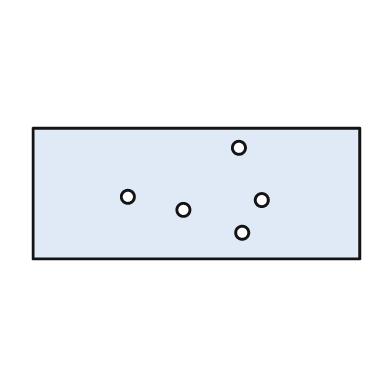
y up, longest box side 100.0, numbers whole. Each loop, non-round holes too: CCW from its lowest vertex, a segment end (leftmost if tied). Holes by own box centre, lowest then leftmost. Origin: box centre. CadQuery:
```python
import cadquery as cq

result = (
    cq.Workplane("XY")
    .moveTo(-50.0, -20.0)
    .lineTo(50.0, -20.0)
    .lineTo(50.0, 20.0)
    .lineTo(-50.0, 20.0)
    .close()
    .moveTo(14.0, -12.0)
    .circle(2.0)
    .moveTo(-4.0, -5.0)
    .circle(2.0)
    .moveTo(20.0, -2.0)
    .circle(2.0)
    .moveTo(-21.0, -1.0)
    .circle(2.0)
    .moveTo(13.0, 14.0)
    .circle(2.0)
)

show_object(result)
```